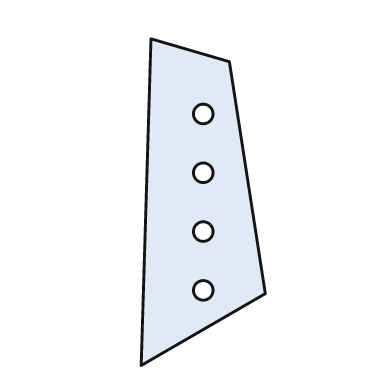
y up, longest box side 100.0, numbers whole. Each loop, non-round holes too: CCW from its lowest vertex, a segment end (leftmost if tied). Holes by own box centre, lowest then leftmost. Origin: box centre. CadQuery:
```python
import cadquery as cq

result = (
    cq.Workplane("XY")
    .moveTo(-19.0, -50.0)
    .lineTo(19.0, -28.0)
    .lineTo(8.0, 43.0)
    .lineTo(-16.0, 50.0)
    .close()
    .moveTo(0.0, -27.0)
    .circle(3.0)
    .moveTo(0.0, -9.0)
    .circle(3.0)
    .moveTo(0.0, 9.0)
    .circle(3.0)
    .moveTo(0.0, 27.0)
    .circle(3.0)
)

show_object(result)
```